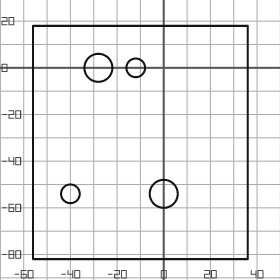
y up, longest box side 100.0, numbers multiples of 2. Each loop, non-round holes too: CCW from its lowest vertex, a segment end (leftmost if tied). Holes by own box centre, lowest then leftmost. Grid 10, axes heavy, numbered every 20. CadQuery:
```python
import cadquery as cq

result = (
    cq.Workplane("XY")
    .moveTo(-56.0, -82.0)
    .lineTo(36.0, -82.0)
    .lineTo(36.0, 18.0)
    .lineTo(-56.0, 18.0)
    .close()
    .moveTo(-40.0, -54.0)
    .circle(4.0)
    .moveTo(0.0, -54.0)
    .circle(6.0)
    .moveTo(-28.0, 0.0)
    .circle(6.0)
    .moveTo(-12.0, 0.0)
    .circle(4.0)
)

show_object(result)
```